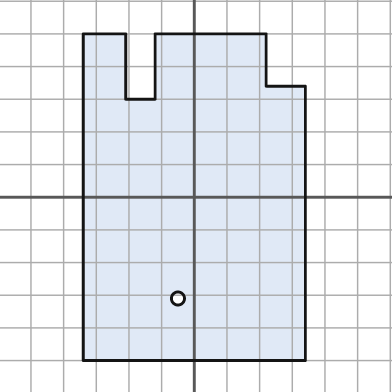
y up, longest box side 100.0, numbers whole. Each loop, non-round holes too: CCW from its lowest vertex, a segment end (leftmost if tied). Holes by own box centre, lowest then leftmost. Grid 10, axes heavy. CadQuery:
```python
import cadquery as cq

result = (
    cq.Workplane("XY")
    .moveTo(-34.0, -50.0)
    .lineTo(34.0, -50.0)
    .lineTo(34.0, 34.0)
    .lineTo(22.0, 34.0)
    .lineTo(22.0, 50.0)
    .lineTo(-12.0, 50.0)
    .lineTo(-12.0, 30.0)
    .lineTo(-21.0, 30.0)
    .lineTo(-21.0, 50.0)
    .lineTo(-34.0, 50.0)
    .close()
    .moveTo(-5.0, -31.0)
    .circle(2.0)
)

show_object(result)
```